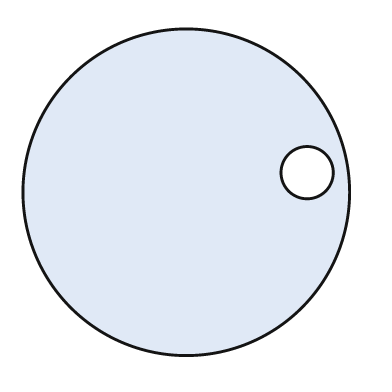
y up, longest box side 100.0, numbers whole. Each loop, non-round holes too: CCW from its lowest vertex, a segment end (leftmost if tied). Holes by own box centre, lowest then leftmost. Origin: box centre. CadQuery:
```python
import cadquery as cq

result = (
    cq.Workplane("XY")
    .moveTo(0.0, 0.0)
    .circle(50.0)
    .moveTo(37.0, 6.0)
    .circle(8.0)
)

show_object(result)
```